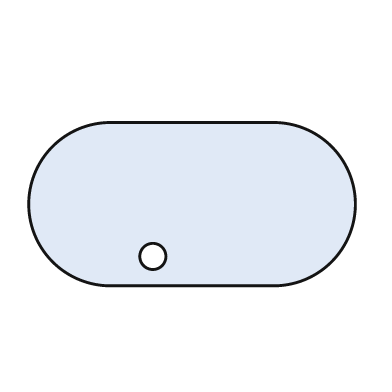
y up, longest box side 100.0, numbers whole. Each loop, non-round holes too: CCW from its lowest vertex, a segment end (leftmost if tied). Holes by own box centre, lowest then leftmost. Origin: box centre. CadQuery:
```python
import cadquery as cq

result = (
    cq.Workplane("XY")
    .moveTo(-25.0, -25.0)
    .lineTo(25.0, -25.0)
    .threePointArc((50.0, 0.0), (25.0, 25.0))
    .lineTo(-25.0, 25.0)
    .threePointArc((-50.0, 0.0), (-25.0, -25.0))
    .close()
    .moveTo(-12.0, -16.0)
    .circle(4.0)
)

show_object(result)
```